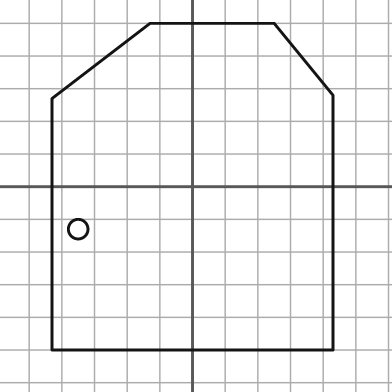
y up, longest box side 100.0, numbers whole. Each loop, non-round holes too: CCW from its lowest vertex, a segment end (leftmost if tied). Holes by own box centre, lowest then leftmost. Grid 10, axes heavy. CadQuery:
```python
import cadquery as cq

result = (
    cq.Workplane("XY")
    .moveTo(-43.0, -50.0)
    .lineTo(43.0, -50.0)
    .lineTo(43.0, 28.0)
    .lineTo(25.0, 50.0)
    .lineTo(-13.0, 50.0)
    .lineTo(-43.0, 27.0)
    .close()
    .moveTo(-35.0, -13.0)
    .circle(3.0)
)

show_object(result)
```